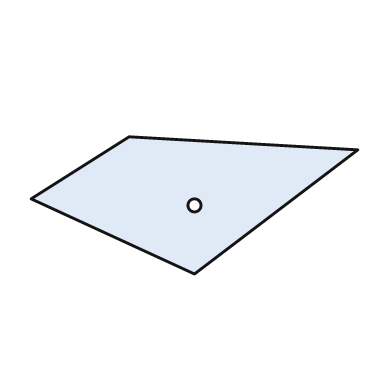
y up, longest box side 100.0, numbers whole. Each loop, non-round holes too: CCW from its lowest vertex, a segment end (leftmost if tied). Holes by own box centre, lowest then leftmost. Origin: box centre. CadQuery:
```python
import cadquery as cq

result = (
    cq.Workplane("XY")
    .moveTo(0.0, -21.0)
    .lineTo(50.0, 17.0)
    .lineTo(-20.0, 21.0)
    .lineTo(-50.0, 2.0)
    .close()
    .moveTo(0.0, 0.0)
    .circle(2.0)
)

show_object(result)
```